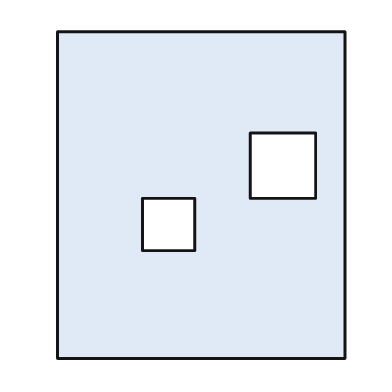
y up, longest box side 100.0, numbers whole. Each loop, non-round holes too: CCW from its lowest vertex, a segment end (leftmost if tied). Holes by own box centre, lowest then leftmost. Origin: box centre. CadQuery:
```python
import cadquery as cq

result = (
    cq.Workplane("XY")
    .moveTo(-44.0, -50.0)
    .lineTo(44.0, -50.0)
    .lineTo(44.0, 50.0)
    .lineTo(-44.0, 50.0)
    .close()
    .moveTo(-18.0, -17.0)
    .lineTo(-2.0, -17.0)
    .lineTo(-2.0, -1.0)
    .lineTo(-18.0, -1.0)
    .close()
    .moveTo(15.0, -1.0)
    .lineTo(35.0, -1.0)
    .lineTo(35.0, 19.0)
    .lineTo(15.0, 19.0)
    .close()
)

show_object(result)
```